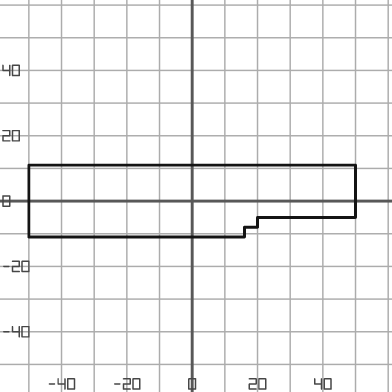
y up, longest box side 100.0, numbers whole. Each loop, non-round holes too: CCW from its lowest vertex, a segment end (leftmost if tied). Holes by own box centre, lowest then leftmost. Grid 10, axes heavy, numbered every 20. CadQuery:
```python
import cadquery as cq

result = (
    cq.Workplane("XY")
    .moveTo(-50.0, -11.0)
    .lineTo(16.0, -11.0)
    .lineTo(16.0, -8.0)
    .lineTo(20.0, -8.0)
    .lineTo(20.0, -5.0)
    .lineTo(50.0, -5.0)
    .lineTo(50.0, 11.0)
    .lineTo(-50.0, 11.0)
    .close()
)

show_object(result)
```